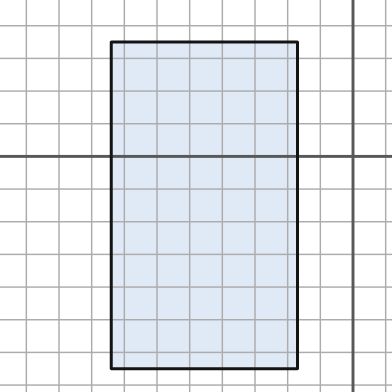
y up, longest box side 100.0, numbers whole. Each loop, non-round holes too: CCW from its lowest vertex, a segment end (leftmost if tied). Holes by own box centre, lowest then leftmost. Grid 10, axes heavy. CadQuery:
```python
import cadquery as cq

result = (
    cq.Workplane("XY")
    .moveTo(-74.0, -65.0)
    .lineTo(-17.0, -65.0)
    .lineTo(-17.0, 35.0)
    .lineTo(-74.0, 35.0)
    .close()
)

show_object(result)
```